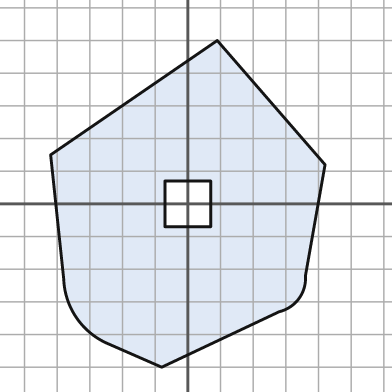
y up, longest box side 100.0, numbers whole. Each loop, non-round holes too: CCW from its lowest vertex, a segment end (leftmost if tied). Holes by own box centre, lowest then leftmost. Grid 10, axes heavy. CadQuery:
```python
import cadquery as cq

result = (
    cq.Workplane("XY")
    .moveTo(-8.0, -50.0)
    .lineTo(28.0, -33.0)
    .threePointArc((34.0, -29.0), (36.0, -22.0))
    .lineTo(42.0, 12.0)
    .lineTo(9.0, 50.0)
    .lineTo(-42.0, 15.0)
    .lineTo(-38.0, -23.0)
    .threePointArc((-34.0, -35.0), (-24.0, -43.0))
    .close()
    .moveTo(-7.0, -7.0)
    .lineTo(7.0, -7.0)
    .lineTo(7.0, 7.0)
    .lineTo(-7.0, 7.0)
    .close()
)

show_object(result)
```